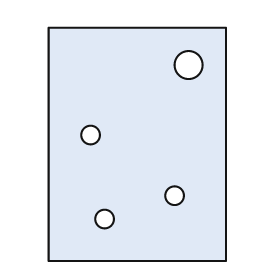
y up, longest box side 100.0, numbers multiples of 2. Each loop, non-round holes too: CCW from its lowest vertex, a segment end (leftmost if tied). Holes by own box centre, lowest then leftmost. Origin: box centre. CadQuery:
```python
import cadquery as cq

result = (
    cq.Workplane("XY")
    .moveTo(-38.0, -50.0)
    .lineTo(38.0, -50.0)
    .lineTo(38.0, 50.0)
    .lineTo(-38.0, 50.0)
    .close()
    .moveTo(-14.0, -32.0)
    .circle(4.0)
    .moveTo(16.0, -22.0)
    .circle(4.0)
    .moveTo(-20.0, 4.0)
    .circle(4.0)
    .moveTo(22.0, 34.0)
    .circle(6.0)
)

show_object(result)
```